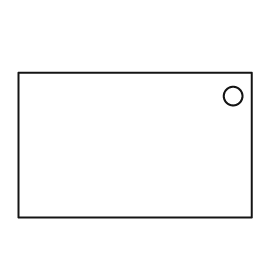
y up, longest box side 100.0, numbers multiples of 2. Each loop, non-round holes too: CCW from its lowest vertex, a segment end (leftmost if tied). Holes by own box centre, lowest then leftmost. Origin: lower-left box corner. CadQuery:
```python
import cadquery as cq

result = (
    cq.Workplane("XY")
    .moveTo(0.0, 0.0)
    .lineTo(100.0, 0.0)
    .lineTo(100.0, 62.0)
    .lineTo(0.0, 62.0)
    .close()
    .moveTo(92.0, 52.0)
    .circle(4.0)
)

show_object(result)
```